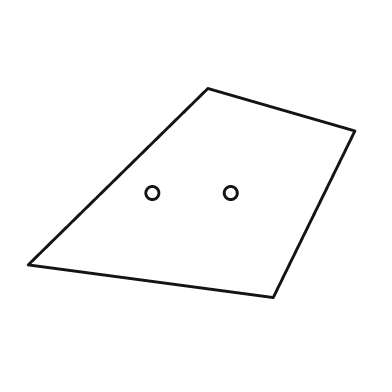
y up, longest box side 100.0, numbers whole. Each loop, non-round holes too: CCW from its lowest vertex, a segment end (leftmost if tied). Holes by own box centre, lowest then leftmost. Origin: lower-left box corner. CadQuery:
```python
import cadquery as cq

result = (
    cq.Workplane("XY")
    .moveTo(75.0, 0.0)
    .lineTo(100.0, 51.0)
    .lineTo(55.0, 64.0)
    .lineTo(0.0, 10.0)
    .close()
    .moveTo(38.0, 32.0)
    .circle(2.0)
    .moveTo(62.0, 32.0)
    .circle(2.0)
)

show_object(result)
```